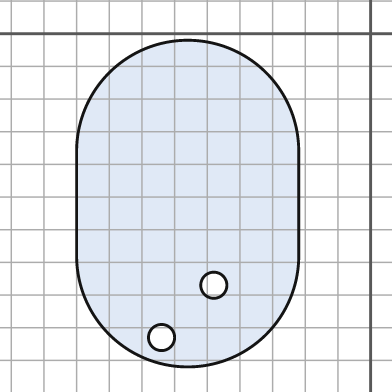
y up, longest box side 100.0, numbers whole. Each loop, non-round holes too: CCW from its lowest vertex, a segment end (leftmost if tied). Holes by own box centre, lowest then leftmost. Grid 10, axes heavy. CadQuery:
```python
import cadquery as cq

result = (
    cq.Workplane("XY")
    .moveTo(-90.0, -68.0)
    .threePointArc((-56.0, -102.0), (-22.0, -68.0))
    .lineTo(-22.0, -36.0)
    .threePointArc((-56.0, -2.0), (-90.0, -36.0))
    .close()
    .moveTo(-64.0, -93.0)
    .circle(4.0)
    .moveTo(-48.0, -77.0)
    .circle(4.0)
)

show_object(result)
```